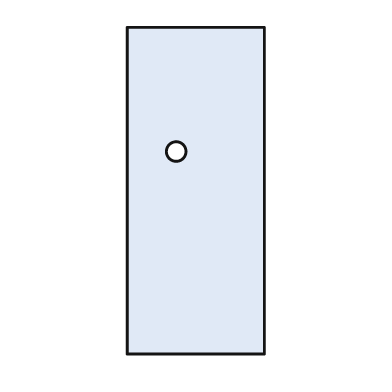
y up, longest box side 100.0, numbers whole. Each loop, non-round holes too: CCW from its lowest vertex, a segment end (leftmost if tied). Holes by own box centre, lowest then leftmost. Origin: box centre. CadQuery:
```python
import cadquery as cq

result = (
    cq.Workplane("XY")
    .moveTo(-21.0, -50.0)
    .lineTo(21.0, -50.0)
    .lineTo(21.0, 50.0)
    .lineTo(-21.0, 50.0)
    .close()
    .moveTo(-6.0, 12.0)
    .circle(3.0)
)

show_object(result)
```